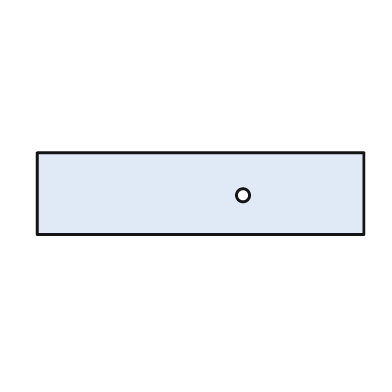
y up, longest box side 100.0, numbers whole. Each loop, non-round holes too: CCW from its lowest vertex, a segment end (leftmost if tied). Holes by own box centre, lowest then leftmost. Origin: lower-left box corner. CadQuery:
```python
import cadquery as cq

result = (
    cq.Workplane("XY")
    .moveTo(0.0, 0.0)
    .lineTo(100.0, 0.0)
    .lineTo(100.0, 25.0)
    .lineTo(0.0, 25.0)
    .close()
    .moveTo(63.0, 12.0)
    .circle(2.0)
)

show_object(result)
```